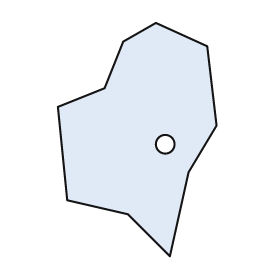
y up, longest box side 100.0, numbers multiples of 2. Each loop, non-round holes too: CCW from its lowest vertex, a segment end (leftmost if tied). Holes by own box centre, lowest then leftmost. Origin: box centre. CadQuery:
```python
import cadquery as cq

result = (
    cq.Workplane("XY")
    .moveTo(14.0, -50.0)
    .lineTo(22.0, -14.0)
    .lineTo(34.0, 6.0)
    .lineTo(30.0, 40.0)
    .lineTo(8.0, 50.0)
    .lineTo(-6.0, 42.0)
    .lineTo(-14.0, 22.0)
    .lineTo(-34.0, 14.0)
    .lineTo(-30.0, -26.0)
    .lineTo(-4.0, -32.0)
    .close()
    .moveTo(12.0, -2.0)
    .circle(4.0)
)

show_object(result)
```